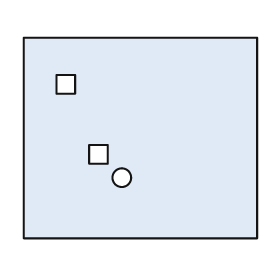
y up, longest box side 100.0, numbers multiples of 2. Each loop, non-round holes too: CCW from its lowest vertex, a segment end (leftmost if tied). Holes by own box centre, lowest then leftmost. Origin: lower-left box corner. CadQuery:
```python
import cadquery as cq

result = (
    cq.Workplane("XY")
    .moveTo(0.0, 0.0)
    .lineTo(100.0, 0.0)
    .lineTo(100.0, 86.0)
    .lineTo(0.0, 86.0)
    .close()
    .moveTo(42.0, 26.0)
    .circle(4.0)
    .moveTo(28.0, 32.0)
    .lineTo(36.0, 32.0)
    .lineTo(36.0, 40.0)
    .lineTo(28.0, 40.0)
    .close()
    .moveTo(14.0, 62.0)
    .lineTo(22.0, 62.0)
    .lineTo(22.0, 70.0)
    .lineTo(14.0, 70.0)
    .close()
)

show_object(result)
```